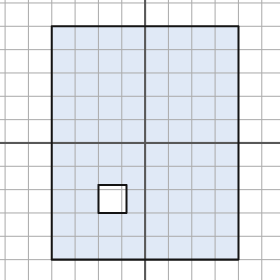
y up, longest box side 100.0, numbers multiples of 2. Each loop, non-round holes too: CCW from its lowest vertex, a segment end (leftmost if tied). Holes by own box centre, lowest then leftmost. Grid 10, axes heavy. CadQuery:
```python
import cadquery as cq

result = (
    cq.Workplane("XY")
    .moveTo(-40.0, -50.0)
    .lineTo(40.0, -50.0)
    .lineTo(40.0, 50.0)
    .lineTo(-40.0, 50.0)
    .close()
    .moveTo(-20.0, -30.0)
    .lineTo(-8.0, -30.0)
    .lineTo(-8.0, -18.0)
    .lineTo(-20.0, -18.0)
    .close()
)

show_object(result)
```